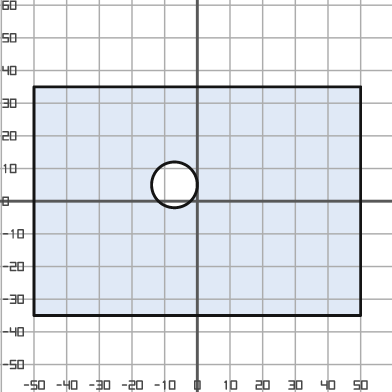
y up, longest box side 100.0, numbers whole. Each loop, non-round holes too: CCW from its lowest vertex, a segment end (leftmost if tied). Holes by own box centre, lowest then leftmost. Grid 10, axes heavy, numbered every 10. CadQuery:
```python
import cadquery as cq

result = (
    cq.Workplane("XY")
    .moveTo(-50.0, -35.0)
    .lineTo(50.0, -35.0)
    .lineTo(50.0, 35.0)
    .lineTo(-50.0, 35.0)
    .close()
    .moveTo(-7.0, 5.0)
    .circle(7.0)
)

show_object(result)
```